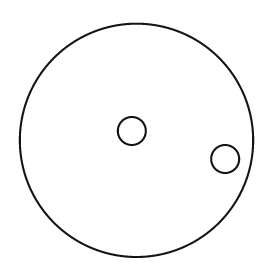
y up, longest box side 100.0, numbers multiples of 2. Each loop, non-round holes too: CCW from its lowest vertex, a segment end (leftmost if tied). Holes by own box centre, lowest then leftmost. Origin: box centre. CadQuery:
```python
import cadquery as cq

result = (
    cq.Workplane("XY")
    .moveTo(0.0, 0.0)
    .circle(50.0)
    .moveTo(38.0, -8.0)
    .circle(6.0)
    .moveTo(-2.0, 4.0)
    .circle(6.0)
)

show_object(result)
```